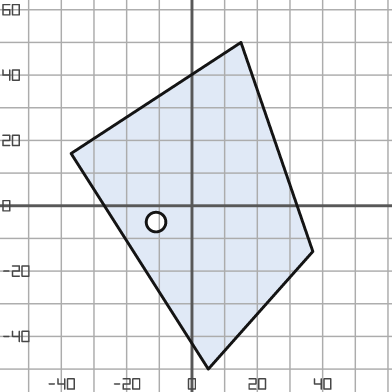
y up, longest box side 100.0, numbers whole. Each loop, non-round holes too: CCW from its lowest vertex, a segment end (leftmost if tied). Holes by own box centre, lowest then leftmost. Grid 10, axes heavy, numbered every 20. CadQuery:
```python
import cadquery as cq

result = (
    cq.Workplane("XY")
    .moveTo(5.0, -50.0)
    .lineTo(37.0, -14.0)
    .lineTo(15.0, 50.0)
    .lineTo(-37.0, 16.0)
    .close()
    .moveTo(-11.0, -5.0)
    .circle(3.0)
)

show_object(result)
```